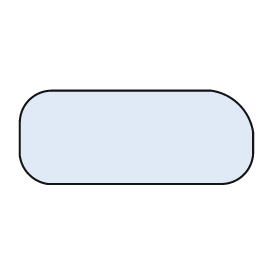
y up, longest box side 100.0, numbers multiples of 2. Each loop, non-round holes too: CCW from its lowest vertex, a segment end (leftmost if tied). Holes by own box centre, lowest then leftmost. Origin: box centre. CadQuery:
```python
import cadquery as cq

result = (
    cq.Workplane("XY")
    .moveTo(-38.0, -20.0)
    .lineTo(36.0, -20.0)
    .threePointArc((46.0, -16.0), (50.0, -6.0))
    .lineTo(50.0, 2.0)
    .threePointArc((44.0, 14.0), (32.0, 20.0))
    .lineTo(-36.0, 20.0)
    .threePointArc((-46.0, 16.0), (-50.0, 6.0))
    .lineTo(-50.0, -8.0)
    .threePointArc((-46.0, -16.0), (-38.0, -20.0))
    .close()
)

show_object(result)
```